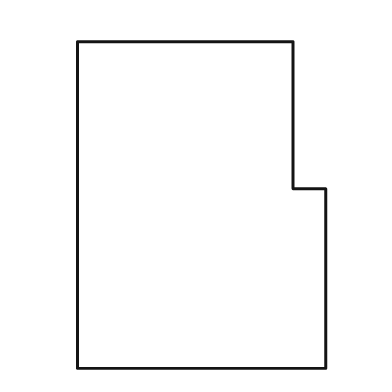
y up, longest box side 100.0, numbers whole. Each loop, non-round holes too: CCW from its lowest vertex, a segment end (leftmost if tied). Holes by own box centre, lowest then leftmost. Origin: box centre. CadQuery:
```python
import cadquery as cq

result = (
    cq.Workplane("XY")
    .moveTo(-38.0, -50.0)
    .lineTo(38.0, -50.0)
    .lineTo(38.0, 5.0)
    .lineTo(28.0, 5.0)
    .lineTo(28.0, 50.0)
    .lineTo(-38.0, 50.0)
    .close()
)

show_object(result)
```